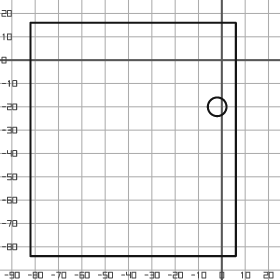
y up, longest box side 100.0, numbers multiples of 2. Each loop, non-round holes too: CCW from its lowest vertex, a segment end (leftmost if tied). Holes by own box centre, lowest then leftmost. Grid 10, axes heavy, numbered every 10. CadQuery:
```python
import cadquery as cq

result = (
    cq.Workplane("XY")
    .moveTo(-82.0, -84.0)
    .lineTo(6.0, -84.0)
    .lineTo(6.0, 16.0)
    .lineTo(-82.0, 16.0)
    .close()
    .moveTo(-2.0, -20.0)
    .circle(4.0)
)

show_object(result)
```